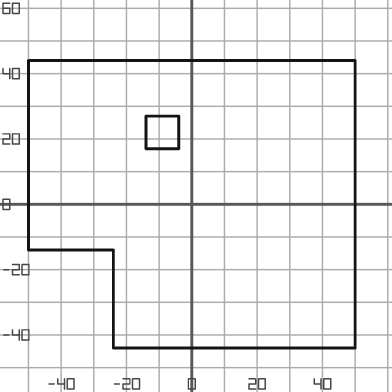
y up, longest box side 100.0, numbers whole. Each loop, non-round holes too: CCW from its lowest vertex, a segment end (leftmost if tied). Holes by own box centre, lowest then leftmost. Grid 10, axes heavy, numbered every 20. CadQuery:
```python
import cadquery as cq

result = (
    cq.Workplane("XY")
    .moveTo(-24.0, -44.0)
    .lineTo(50.0, -44.0)
    .lineTo(50.0, 44.0)
    .lineTo(-50.0, 44.0)
    .lineTo(-50.0, -14.0)
    .lineTo(-24.0, -14.0)
    .close()
    .moveTo(-14.0, 17.0)
    .lineTo(-4.0, 17.0)
    .lineTo(-4.0, 27.0)
    .lineTo(-14.0, 27.0)
    .close()
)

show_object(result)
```